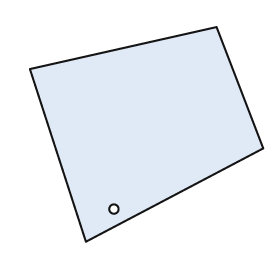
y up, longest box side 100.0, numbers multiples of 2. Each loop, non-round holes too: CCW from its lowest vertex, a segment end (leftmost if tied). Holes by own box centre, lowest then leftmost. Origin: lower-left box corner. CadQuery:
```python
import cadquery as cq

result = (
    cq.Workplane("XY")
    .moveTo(24.0, 0.0)
    .lineTo(100.0, 40.0)
    .lineTo(80.0, 92.0)
    .lineTo(0.0, 74.0)
    .close()
    .moveTo(36.0, 14.0)
    .circle(2.0)
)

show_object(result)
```